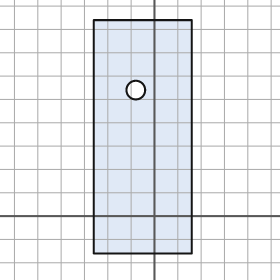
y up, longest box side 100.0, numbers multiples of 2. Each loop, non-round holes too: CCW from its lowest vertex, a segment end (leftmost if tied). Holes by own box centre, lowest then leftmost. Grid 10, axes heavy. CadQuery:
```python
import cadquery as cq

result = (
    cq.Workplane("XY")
    .moveTo(-26.0, -16.0)
    .lineTo(16.0, -16.0)
    .lineTo(16.0, 84.0)
    .lineTo(-26.0, 84.0)
    .close()
    .moveTo(-8.0, 54.0)
    .circle(4.0)
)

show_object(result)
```